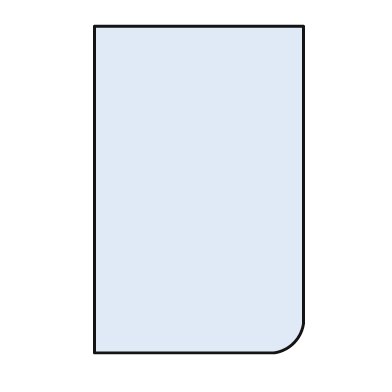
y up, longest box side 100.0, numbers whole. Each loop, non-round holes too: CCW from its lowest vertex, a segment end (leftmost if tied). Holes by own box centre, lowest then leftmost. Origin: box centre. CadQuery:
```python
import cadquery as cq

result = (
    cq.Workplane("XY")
    .moveTo(-32.0, -50.0)
    .lineTo(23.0, -50.0)
    .threePointArc((29.0, -47.0), (32.0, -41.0))
    .lineTo(32.0, 50.0)
    .lineTo(-32.0, 50.0)
    .close()
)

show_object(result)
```